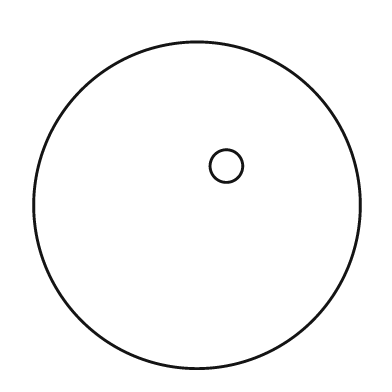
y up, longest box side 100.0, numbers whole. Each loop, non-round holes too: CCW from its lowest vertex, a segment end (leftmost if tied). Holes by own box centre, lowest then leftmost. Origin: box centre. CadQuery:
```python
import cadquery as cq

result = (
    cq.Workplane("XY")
    .moveTo(0.0, 0.0)
    .circle(50.0)
    .moveTo(9.0, 12.0)
    .circle(5.0)
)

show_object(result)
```